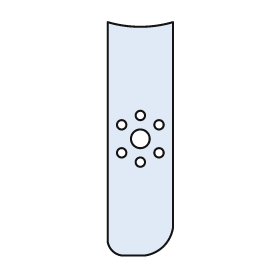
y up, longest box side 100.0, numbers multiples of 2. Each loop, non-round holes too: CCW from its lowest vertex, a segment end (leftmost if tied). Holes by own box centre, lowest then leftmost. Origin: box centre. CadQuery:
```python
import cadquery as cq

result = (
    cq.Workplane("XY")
    .moveTo(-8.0, -50.0)
    .lineTo(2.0, -50.0)
    .threePointArc((10.0, -46.0), (14.0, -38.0))
    .lineTo(14.0, 50.0)
    .threePointArc((0.0, 48.0), (-14.0, 50.0))
    .lineTo(-14.0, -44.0)
    .threePointArc((-12.0, -48.0), (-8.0, -50.0))
    .close()
    .moveTo(0.0, -10.0)
    .circle(2.0)
    .moveTo(-8.0, -6.0)
    .circle(2.0)
    .moveTo(8.0, -6.0)
    .circle(2.0)
    .moveTo(0.0, 0.0)
    .circle(4.0)
    .moveTo(-8.0, 6.0)
    .circle(2.0)
    .moveTo(8.0, 6.0)
    .circle(2.0)
    .moveTo(0.0, 10.0)
    .circle(2.0)
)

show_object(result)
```